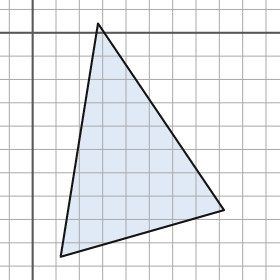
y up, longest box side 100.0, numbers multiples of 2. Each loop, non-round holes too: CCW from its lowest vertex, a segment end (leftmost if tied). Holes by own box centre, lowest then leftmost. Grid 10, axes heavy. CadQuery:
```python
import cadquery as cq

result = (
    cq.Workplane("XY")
    .moveTo(12.0, -96.0)
    .lineTo(82.0, -76.0)
    .lineTo(28.0, 4.0)
    .close()
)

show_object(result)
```